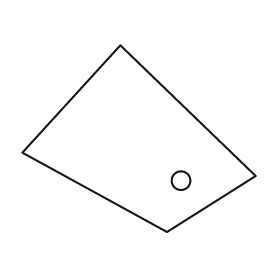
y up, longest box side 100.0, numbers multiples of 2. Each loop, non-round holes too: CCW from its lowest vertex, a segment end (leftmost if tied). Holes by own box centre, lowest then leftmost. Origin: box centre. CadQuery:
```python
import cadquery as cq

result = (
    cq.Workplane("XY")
    .moveTo(12.0, -40.0)
    .lineTo(50.0, -16.0)
    .lineTo(-8.0, 40.0)
    .lineTo(-50.0, -6.0)
    .close()
    .moveTo(18.0, -18.0)
    .circle(4.0)
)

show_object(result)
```